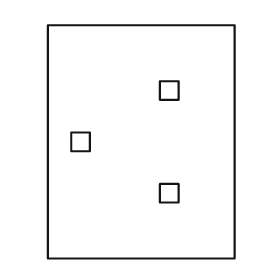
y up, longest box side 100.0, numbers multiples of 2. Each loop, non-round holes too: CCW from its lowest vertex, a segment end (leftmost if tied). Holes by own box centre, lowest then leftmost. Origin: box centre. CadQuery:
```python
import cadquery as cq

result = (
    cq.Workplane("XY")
    .moveTo(-40.0, -50.0)
    .lineTo(40.0, -50.0)
    .lineTo(40.0, 50.0)
    .lineTo(-40.0, 50.0)
    .close()
    .moveTo(8.0, -26.0)
    .lineTo(16.0, -26.0)
    .lineTo(16.0, -18.0)
    .lineTo(8.0, -18.0)
    .close()
    .moveTo(-30.0, -4.0)
    .lineTo(-22.0, -4.0)
    .lineTo(-22.0, 4.0)
    .lineTo(-30.0, 4.0)
    .close()
    .moveTo(8.0, 18.0)
    .lineTo(16.0, 18.0)
    .lineTo(16.0, 26.0)
    .lineTo(8.0, 26.0)
    .close()
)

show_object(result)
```